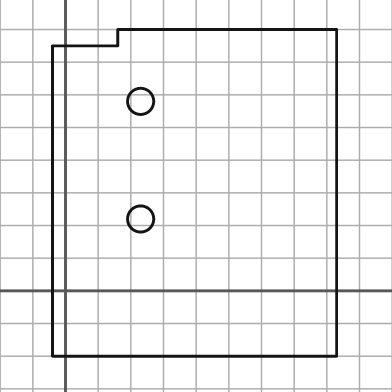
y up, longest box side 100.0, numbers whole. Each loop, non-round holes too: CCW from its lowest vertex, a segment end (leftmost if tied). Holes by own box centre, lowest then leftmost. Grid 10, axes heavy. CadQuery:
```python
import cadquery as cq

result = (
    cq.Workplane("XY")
    .moveTo(-4.0, -20.0)
    .lineTo(83.0, -20.0)
    .lineTo(83.0, 80.0)
    .lineTo(16.0, 80.0)
    .lineTo(16.0, 75.0)
    .lineTo(-4.0, 75.0)
    .close()
    .moveTo(23.0, 22.0)
    .circle(4.0)
    .moveTo(23.0, 58.0)
    .circle(4.0)
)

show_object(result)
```